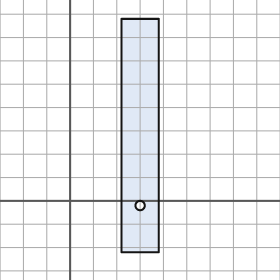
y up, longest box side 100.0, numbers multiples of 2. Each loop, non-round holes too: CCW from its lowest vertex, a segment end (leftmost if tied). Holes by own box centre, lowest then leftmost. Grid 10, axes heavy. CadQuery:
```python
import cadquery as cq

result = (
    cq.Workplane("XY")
    .moveTo(22.0, -22.0)
    .lineTo(38.0, -22.0)
    .lineTo(38.0, 78.0)
    .lineTo(22.0, 78.0)
    .close()
    .moveTo(30.0, -2.0)
    .circle(2.0)
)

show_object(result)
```